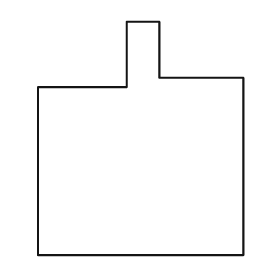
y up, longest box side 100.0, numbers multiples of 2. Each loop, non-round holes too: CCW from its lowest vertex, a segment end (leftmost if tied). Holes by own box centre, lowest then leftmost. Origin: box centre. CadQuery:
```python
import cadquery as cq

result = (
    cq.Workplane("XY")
    .moveTo(-44.0, -50.0)
    .lineTo(44.0, -50.0)
    .lineTo(44.0, 26.0)
    .lineTo(8.0, 26.0)
    .lineTo(8.0, 50.0)
    .lineTo(-6.0, 50.0)
    .lineTo(-6.0, 22.0)
    .lineTo(-44.0, 22.0)
    .close()
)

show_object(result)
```